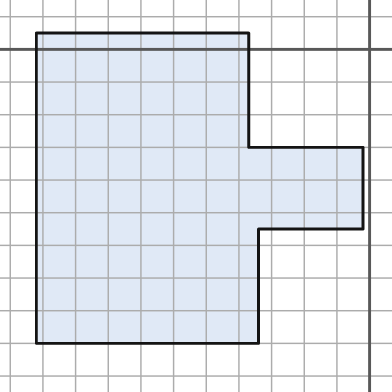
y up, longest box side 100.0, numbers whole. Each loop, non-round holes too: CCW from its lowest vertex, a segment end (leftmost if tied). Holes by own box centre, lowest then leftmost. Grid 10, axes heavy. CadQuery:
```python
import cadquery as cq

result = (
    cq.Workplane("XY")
    .moveTo(-102.0, -90.0)
    .lineTo(-34.0, -90.0)
    .lineTo(-34.0, -55.0)
    .lineTo(-2.0, -55.0)
    .lineTo(-2.0, -30.0)
    .lineTo(-37.0, -30.0)
    .lineTo(-37.0, 5.0)
    .lineTo(-102.0, 5.0)
    .close()
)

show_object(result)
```